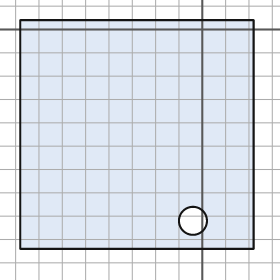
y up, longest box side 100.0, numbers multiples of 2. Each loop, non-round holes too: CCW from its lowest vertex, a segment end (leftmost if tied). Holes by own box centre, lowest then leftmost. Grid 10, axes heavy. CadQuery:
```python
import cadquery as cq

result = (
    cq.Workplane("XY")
    .moveTo(-78.0, -94.0)
    .lineTo(22.0, -94.0)
    .lineTo(22.0, 4.0)
    .lineTo(-78.0, 4.0)
    .close()
    .moveTo(-4.0, -82.0)
    .circle(6.0)
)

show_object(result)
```